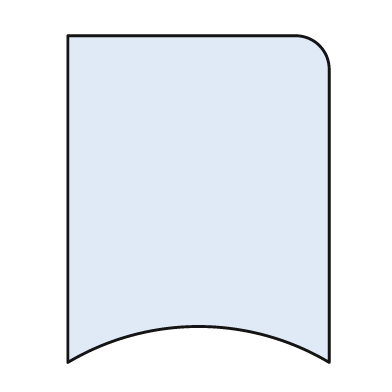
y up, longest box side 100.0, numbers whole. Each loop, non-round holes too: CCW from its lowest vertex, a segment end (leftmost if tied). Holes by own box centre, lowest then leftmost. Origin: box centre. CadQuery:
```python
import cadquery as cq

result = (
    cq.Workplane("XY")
    .moveTo(-40.0, -50.0)
    .threePointArc((0.0, -39.0), (40.0, -50.0))
    .lineTo(40.0, 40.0)
    .threePointArc((37.0, 47.0), (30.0, 50.0))
    .lineTo(-40.0, 50.0)
    .close()
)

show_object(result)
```